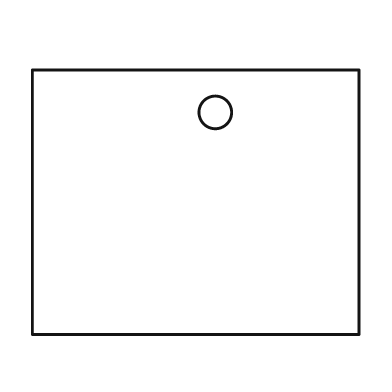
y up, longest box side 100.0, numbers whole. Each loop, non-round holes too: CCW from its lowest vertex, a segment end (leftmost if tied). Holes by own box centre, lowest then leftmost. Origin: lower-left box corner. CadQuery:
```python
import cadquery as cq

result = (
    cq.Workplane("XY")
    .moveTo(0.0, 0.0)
    .lineTo(100.0, 0.0)
    .lineTo(100.0, 81.0)
    .lineTo(0.0, 81.0)
    .close()
    .moveTo(56.0, 68.0)
    .circle(5.0)
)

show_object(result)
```